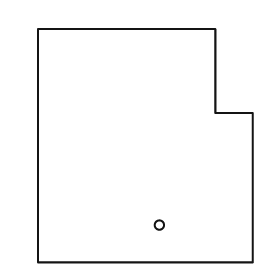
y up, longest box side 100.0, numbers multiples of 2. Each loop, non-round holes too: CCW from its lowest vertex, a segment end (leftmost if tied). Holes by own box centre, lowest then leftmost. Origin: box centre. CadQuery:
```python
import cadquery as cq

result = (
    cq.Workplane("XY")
    .moveTo(-46.0, -50.0)
    .lineTo(46.0, -50.0)
    .lineTo(46.0, 14.0)
    .lineTo(30.0, 14.0)
    .lineTo(30.0, 50.0)
    .lineTo(-46.0, 50.0)
    .close()
    .moveTo(6.0, -34.0)
    .circle(2.0)
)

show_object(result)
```